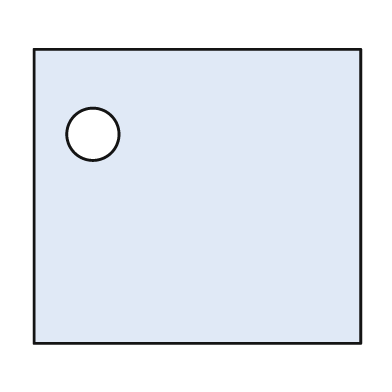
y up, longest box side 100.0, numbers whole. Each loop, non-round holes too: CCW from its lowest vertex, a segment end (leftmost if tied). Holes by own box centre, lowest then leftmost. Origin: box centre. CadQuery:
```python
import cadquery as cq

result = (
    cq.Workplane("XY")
    .moveTo(-50.0, -45.0)
    .lineTo(50.0, -45.0)
    .lineTo(50.0, 45.0)
    .lineTo(-50.0, 45.0)
    .close()
    .moveTo(-32.0, 19.0)
    .circle(8.0)
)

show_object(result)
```